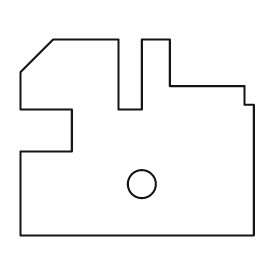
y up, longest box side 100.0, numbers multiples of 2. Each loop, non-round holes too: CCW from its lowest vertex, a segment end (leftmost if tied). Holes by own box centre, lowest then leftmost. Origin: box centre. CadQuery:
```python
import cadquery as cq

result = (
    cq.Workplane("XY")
    .moveTo(-50.0, -42.0)
    .lineTo(50.0, -42.0)
    .lineTo(50.0, 14.0)
    .lineTo(46.0, 14.0)
    .lineTo(46.0, 22.0)
    .lineTo(14.0, 22.0)
    .lineTo(14.0, 42.0)
    .lineTo(2.0, 42.0)
    .lineTo(2.0, 12.0)
    .lineTo(-8.0, 12.0)
    .lineTo(-8.0, 42.0)
    .lineTo(-36.0, 42.0)
    .lineTo(-50.0, 28.0)
    .lineTo(-50.0, 12.0)
    .lineTo(-28.0, 12.0)
    .lineTo(-28.0, -6.0)
    .lineTo(-50.0, -6.0)
    .close()
    .moveTo(2.0, -20.0)
    .circle(6.0)
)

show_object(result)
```